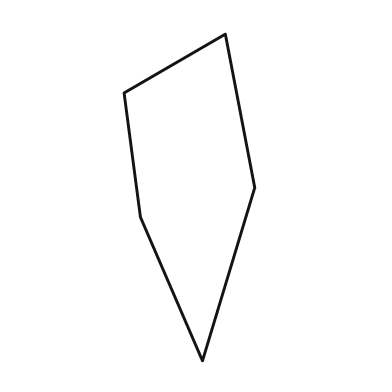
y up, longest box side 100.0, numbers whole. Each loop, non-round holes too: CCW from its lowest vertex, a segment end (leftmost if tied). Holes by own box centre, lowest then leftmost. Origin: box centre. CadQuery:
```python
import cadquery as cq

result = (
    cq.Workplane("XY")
    .moveTo(4.0, -50.0)
    .lineTo(20.0, 3.0)
    .lineTo(11.0, 50.0)
    .lineTo(-20.0, 32.0)
    .lineTo(-15.0, -6.0)
    .close()
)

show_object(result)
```